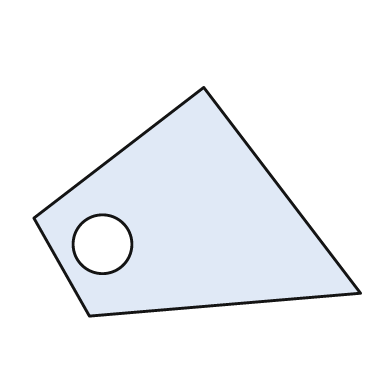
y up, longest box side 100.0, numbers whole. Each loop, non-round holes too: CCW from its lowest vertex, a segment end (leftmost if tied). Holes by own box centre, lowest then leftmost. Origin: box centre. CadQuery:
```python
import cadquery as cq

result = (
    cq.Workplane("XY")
    .moveTo(-33.0, -35.0)
    .lineTo(50.0, -28.0)
    .lineTo(2.0, 35.0)
    .lineTo(-50.0, -5.0)
    .close()
    .moveTo(-29.0, -13.0)
    .circle(9.0)
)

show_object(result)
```